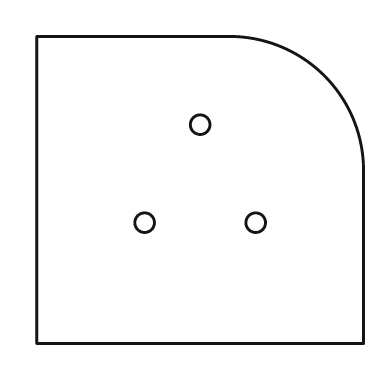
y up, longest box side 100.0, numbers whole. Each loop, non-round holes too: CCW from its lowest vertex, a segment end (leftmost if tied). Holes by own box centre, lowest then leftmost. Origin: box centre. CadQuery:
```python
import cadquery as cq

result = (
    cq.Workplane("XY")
    .moveTo(-50.0, -47.0)
    .lineTo(50.0, -47.0)
    .lineTo(50.0, 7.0)
    .threePointArc((38.0, 35.0), (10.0, 47.0))
    .lineTo(-50.0, 47.0)
    .close()
    .moveTo(-17.0, -10.0)
    .circle(3.0)
    .moveTo(17.0, -10.0)
    .circle(3.0)
    .moveTo(0.0, 20.0)
    .circle(3.0)
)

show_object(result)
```